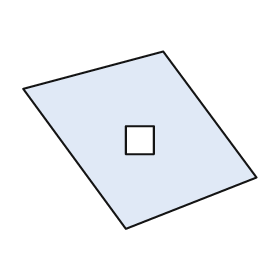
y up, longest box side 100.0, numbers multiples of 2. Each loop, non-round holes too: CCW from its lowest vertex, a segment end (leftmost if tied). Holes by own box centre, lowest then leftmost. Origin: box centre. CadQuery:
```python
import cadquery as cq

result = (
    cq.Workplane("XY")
    .moveTo(-6.0, -38.0)
    .lineTo(50.0, -16.0)
    .lineTo(10.0, 38.0)
    .lineTo(-50.0, 22.0)
    .close()
    .moveTo(-6.0, -6.0)
    .lineTo(6.0, -6.0)
    .lineTo(6.0, 6.0)
    .lineTo(-6.0, 6.0)
    .close()
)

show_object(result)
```